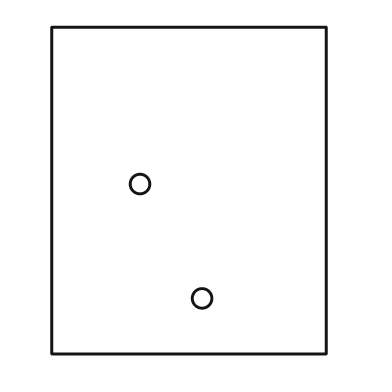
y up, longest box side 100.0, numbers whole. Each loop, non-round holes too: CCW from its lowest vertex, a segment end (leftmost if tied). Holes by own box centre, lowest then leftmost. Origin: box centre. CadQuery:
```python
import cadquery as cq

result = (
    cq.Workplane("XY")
    .moveTo(-42.0, -50.0)
    .lineTo(42.0, -50.0)
    .lineTo(42.0, 50.0)
    .lineTo(-42.0, 50.0)
    .close()
    .moveTo(4.0, -33.0)
    .circle(3.0)
    .moveTo(-15.0, 2.0)
    .circle(3.0)
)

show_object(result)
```